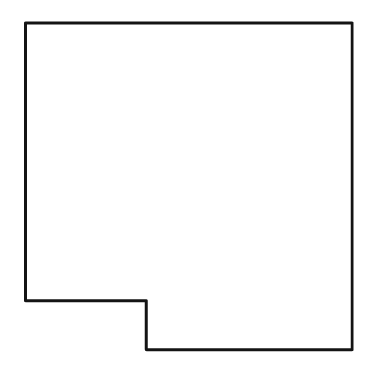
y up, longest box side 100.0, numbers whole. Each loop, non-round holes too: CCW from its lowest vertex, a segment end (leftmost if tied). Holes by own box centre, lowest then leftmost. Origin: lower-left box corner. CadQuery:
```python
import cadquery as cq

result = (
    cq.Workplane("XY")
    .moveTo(37.0, 0.0)
    .lineTo(100.0, 0.0)
    .lineTo(100.0, 100.0)
    .lineTo(0.0, 100.0)
    .lineTo(0.0, 15.0)
    .lineTo(37.0, 15.0)
    .close()
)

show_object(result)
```